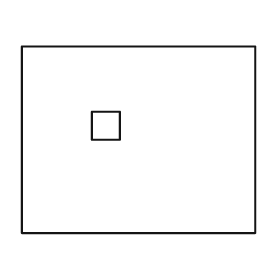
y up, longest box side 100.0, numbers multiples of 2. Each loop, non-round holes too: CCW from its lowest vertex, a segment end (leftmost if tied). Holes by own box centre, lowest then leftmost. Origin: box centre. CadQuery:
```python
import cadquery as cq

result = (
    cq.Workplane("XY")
    .moveTo(-50.0, -40.0)
    .lineTo(50.0, -40.0)
    .lineTo(50.0, 40.0)
    .lineTo(-50.0, 40.0)
    .close()
    .moveTo(-20.0, 0.0)
    .lineTo(-8.0, 0.0)
    .lineTo(-8.0, 12.0)
    .lineTo(-20.0, 12.0)
    .close()
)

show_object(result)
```